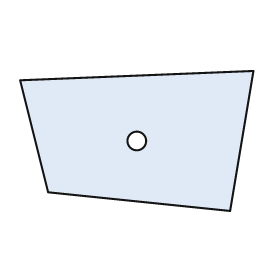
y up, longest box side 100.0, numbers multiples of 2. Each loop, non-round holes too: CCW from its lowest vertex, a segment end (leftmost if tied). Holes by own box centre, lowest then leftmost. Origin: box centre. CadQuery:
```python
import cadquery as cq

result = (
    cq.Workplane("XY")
    .moveTo(40.0, -30.0)
    .lineTo(50.0, 30.0)
    .lineTo(-50.0, 26.0)
    .lineTo(-38.0, -22.0)
    .close()
    .moveTo(0.0, 0.0)
    .circle(4.0)
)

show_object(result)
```